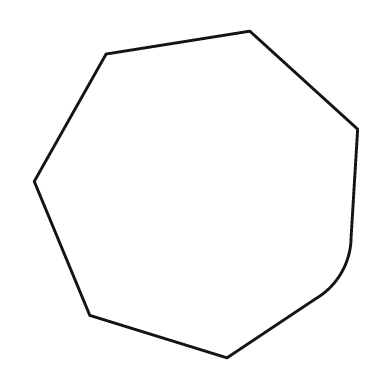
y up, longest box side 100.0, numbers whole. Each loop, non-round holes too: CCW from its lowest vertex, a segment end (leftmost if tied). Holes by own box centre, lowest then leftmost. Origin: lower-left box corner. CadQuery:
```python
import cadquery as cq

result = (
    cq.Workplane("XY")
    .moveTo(59.0, 0.0)
    .lineTo(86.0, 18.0)
    .threePointArc((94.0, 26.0), (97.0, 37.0))
    .lineTo(99.0, 70.0)
    .lineTo(66.0, 100.0)
    .lineTo(22.0, 93.0)
    .lineTo(0.0, 54.0)
    .lineTo(17.0, 13.0)
    .close()
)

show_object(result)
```